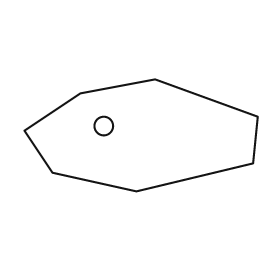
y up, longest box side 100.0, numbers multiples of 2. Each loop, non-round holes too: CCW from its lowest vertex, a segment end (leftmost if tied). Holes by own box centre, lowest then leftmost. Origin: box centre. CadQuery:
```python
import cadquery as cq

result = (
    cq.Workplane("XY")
    .moveTo(-2.0, -24.0)
    .lineTo(48.0, -12.0)
    .lineTo(50.0, 8.0)
    .lineTo(6.0, 24.0)
    .lineTo(-26.0, 18.0)
    .lineTo(-50.0, 2.0)
    .lineTo(-38.0, -16.0)
    .close()
    .moveTo(-16.0, 4.0)
    .circle(4.0)
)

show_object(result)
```